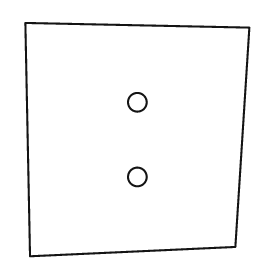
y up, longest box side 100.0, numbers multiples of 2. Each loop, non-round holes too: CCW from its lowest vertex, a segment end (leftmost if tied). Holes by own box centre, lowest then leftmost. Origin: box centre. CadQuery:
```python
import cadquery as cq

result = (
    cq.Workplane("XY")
    .moveTo(-46.0, -50.0)
    .lineTo(42.0, -46.0)
    .lineTo(48.0, 48.0)
    .lineTo(-48.0, 50.0)
    .close()
    .moveTo(0.0, -16.0)
    .circle(4.0)
    .moveTo(0.0, 16.0)
    .circle(4.0)
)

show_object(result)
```